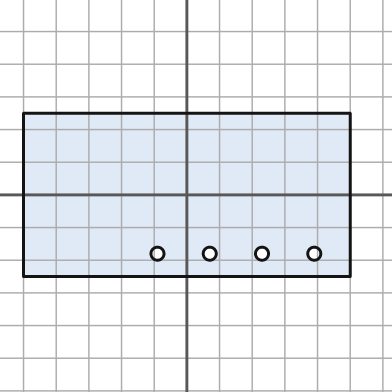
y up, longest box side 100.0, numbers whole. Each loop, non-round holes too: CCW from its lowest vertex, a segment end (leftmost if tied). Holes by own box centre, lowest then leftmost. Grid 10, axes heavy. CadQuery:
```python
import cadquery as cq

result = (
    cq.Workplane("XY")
    .moveTo(-50.0, -25.0)
    .lineTo(50.0, -25.0)
    .lineTo(50.0, 25.0)
    .lineTo(-50.0, 25.0)
    .close()
    .moveTo(-9.0, -18.0)
    .circle(2.0)
    .moveTo(7.0, -18.0)
    .circle(2.0)
    .moveTo(23.0, -18.0)
    .circle(2.0)
    .moveTo(39.0, -18.0)
    .circle(2.0)
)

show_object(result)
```